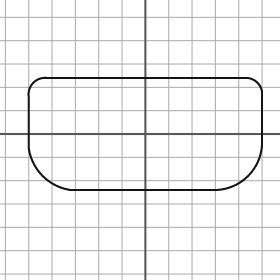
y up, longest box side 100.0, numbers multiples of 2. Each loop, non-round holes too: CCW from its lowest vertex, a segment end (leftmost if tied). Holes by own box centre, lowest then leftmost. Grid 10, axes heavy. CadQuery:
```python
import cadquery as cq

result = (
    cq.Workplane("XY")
    .moveTo(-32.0, -24.0)
    .lineTo(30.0, -24.0)
    .threePointArc((44.0, -18.0), (50.0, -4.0))
    .lineTo(50.0, 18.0)
    .threePointArc((48.0, 22.0), (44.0, 24.0))
    .lineTo(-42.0, 24.0)
    .threePointArc((-48.0, 22.0), (-50.0, 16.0))
    .lineTo(-50.0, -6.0)
    .threePointArc((-44.0, -18.0), (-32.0, -24.0))
    .close()
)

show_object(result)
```